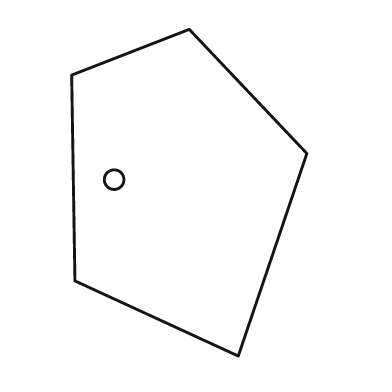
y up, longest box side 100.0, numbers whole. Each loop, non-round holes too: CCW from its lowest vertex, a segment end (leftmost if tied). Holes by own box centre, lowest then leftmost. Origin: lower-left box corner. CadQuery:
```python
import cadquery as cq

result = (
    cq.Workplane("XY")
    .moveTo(51.0, 0.0)
    .lineTo(72.0, 62.0)
    .lineTo(36.0, 100.0)
    .lineTo(0.0, 86.0)
    .lineTo(1.0, 23.0)
    .close()
    .moveTo(13.0, 54.0)
    .circle(3.0)
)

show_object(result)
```